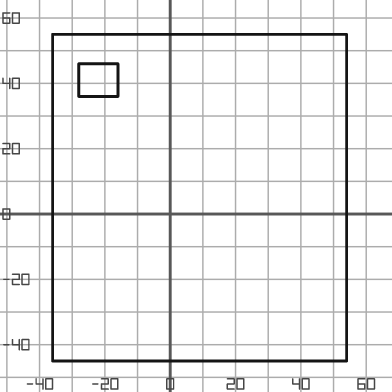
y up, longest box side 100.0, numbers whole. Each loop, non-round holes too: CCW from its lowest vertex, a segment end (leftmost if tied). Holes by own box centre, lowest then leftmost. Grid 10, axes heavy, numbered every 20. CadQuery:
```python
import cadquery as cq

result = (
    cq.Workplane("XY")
    .moveTo(-36.0, -45.0)
    .lineTo(54.0, -45.0)
    .lineTo(54.0, 55.0)
    .lineTo(-36.0, 55.0)
    .close()
    .moveTo(-28.0, 36.0)
    .lineTo(-16.0, 36.0)
    .lineTo(-16.0, 46.0)
    .lineTo(-28.0, 46.0)
    .close()
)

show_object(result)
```